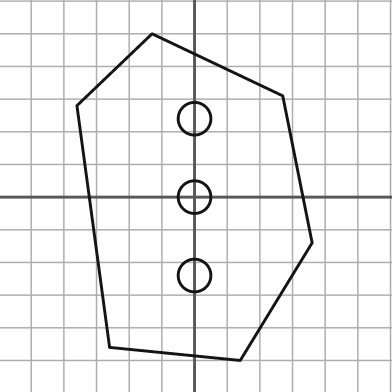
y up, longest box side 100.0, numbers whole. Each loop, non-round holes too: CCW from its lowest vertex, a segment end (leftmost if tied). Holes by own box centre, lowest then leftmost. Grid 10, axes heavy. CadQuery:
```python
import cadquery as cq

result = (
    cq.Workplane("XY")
    .moveTo(14.0, -50.0)
    .lineTo(36.0, -14.0)
    .lineTo(27.0, 31.0)
    .lineTo(-13.0, 50.0)
    .lineTo(-36.0, 28.0)
    .lineTo(-26.0, -46.0)
    .close()
    .moveTo(0.0, -24.0)
    .circle(5.0)
    .moveTo(0.0, 0.0)
    .circle(5.0)
    .moveTo(0.0, 24.0)
    .circle(5.0)
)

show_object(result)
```